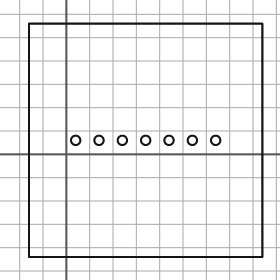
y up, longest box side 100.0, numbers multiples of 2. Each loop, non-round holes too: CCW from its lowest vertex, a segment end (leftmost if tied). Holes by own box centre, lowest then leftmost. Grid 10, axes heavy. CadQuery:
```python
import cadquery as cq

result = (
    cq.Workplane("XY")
    .moveTo(-16.0, -44.0)
    .lineTo(84.0, -44.0)
    .lineTo(84.0, 56.0)
    .lineTo(-16.0, 56.0)
    .close()
    .moveTo(4.0, 6.0)
    .circle(2.0)
    .moveTo(14.0, 6.0)
    .circle(2.0)
    .moveTo(24.0, 6.0)
    .circle(2.0)
    .moveTo(34.0, 6.0)
    .circle(2.0)
    .moveTo(44.0, 6.0)
    .circle(2.0)
    .moveTo(54.0, 6.0)
    .circle(2.0)
    .moveTo(64.0, 6.0)
    .circle(2.0)
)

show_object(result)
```